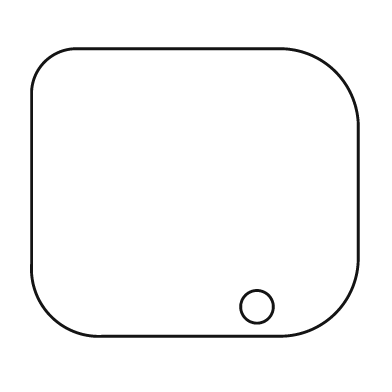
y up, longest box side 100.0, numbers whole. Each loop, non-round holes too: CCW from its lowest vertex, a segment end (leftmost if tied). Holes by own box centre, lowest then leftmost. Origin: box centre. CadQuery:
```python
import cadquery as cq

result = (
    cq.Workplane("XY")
    .moveTo(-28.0, -44.0)
    .lineTo(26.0, -44.0)
    .threePointArc((43.0, -37.0), (50.0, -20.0))
    .lineTo(50.0, 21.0)
    .threePointArc((43.0, 37.0), (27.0, 44.0))
    .lineTo(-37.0, 44.0)
    .threePointArc((-46.0, 40.0), (-50.0, 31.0))
    .lineTo(-50.0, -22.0)
    .threePointArc((-44.0, -38.0), (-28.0, -44.0))
    .close()
    .moveTo(19.0, -35.0)
    .circle(5.0)
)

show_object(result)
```